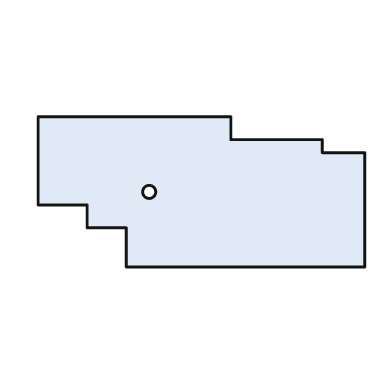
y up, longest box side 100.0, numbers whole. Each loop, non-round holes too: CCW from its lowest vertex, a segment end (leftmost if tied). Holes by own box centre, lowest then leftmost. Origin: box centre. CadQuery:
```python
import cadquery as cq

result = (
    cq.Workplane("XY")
    .moveTo(-23.0, -23.0)
    .lineTo(50.0, -23.0)
    .lineTo(50.0, 12.0)
    .lineTo(37.0, 12.0)
    .lineTo(37.0, 16.0)
    .lineTo(9.0, 16.0)
    .lineTo(9.0, 23.0)
    .lineTo(-50.0, 23.0)
    .lineTo(-50.0, -4.0)
    .lineTo(-35.0, -4.0)
    .lineTo(-35.0, -11.0)
    .lineTo(-23.0, -11.0)
    .close()
    .moveTo(-16.0, 0.0)
    .circle(2.0)
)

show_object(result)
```